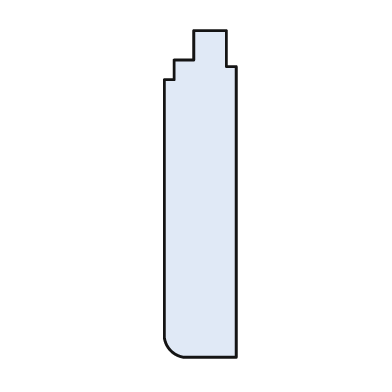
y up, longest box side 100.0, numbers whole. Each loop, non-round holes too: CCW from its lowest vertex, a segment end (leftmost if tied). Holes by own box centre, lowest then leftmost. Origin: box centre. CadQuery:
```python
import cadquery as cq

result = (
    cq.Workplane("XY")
    .moveTo(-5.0, -50.0)
    .lineTo(11.0, -50.0)
    .lineTo(11.0, 39.0)
    .lineTo(8.0, 39.0)
    .lineTo(8.0, 50.0)
    .lineTo(-2.0, 50.0)
    .lineTo(-2.0, 41.0)
    .lineTo(-8.0, 41.0)
    .lineTo(-8.0, 35.0)
    .lineTo(-11.0, 35.0)
    .lineTo(-11.0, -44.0)
    .threePointArc((-9.0, -48.0), (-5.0, -50.0))
    .close()
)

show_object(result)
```